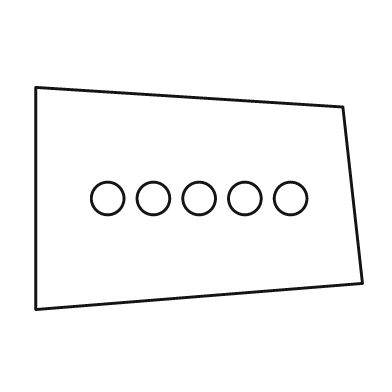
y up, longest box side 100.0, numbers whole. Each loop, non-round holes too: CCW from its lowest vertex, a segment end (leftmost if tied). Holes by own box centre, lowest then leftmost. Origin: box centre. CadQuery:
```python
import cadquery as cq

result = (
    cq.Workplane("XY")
    .moveTo(-50.0, -34.0)
    .lineTo(50.0, -26.0)
    .lineTo(44.0, 28.0)
    .lineTo(-50.0, 34.0)
    .close()
    .moveTo(-28.0, 0.0)
    .circle(5.0)
    .moveTo(-14.0, 0.0)
    .circle(5.0)
    .moveTo(0.0, 0.0)
    .circle(5.0)
    .moveTo(14.0, 0.0)
    .circle(5.0)
    .moveTo(28.0, 0.0)
    .circle(5.0)
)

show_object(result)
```